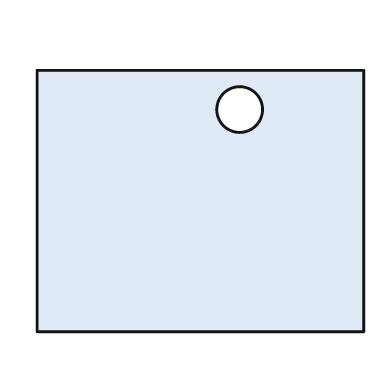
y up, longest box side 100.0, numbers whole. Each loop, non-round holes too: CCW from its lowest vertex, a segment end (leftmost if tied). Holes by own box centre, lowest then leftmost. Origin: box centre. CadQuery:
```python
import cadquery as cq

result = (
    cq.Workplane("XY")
    .moveTo(-50.0, -40.0)
    .lineTo(50.0, -40.0)
    .lineTo(50.0, 40.0)
    .lineTo(-50.0, 40.0)
    .close()
    .moveTo(12.0, 28.0)
    .circle(7.0)
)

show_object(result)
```